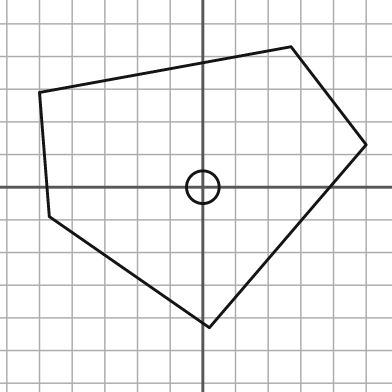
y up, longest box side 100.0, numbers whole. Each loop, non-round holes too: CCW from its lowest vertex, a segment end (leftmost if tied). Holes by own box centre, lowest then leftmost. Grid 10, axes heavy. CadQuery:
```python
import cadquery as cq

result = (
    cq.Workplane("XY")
    .moveTo(2.0, -43.0)
    .lineTo(50.0, 13.0)
    .lineTo(27.0, 43.0)
    .lineTo(-50.0, 29.0)
    .lineTo(-47.0, -9.0)
    .close()
    .moveTo(0.0, 0.0)
    .circle(5.0)
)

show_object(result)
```